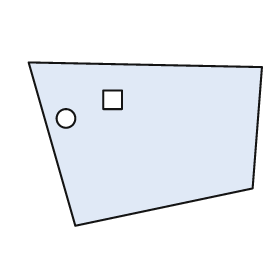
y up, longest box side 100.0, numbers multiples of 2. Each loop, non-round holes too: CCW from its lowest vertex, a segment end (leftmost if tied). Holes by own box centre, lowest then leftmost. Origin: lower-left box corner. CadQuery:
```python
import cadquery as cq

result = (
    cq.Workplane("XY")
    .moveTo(20.0, 0.0)
    .lineTo(96.0, 16.0)
    .lineTo(100.0, 68.0)
    .lineTo(0.0, 70.0)
    .close()
    .moveTo(16.0, 46.0)
    .circle(4.0)
    .moveTo(32.0, 50.0)
    .lineTo(40.0, 50.0)
    .lineTo(40.0, 58.0)
    .lineTo(32.0, 58.0)
    .close()
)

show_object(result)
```